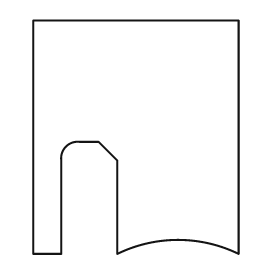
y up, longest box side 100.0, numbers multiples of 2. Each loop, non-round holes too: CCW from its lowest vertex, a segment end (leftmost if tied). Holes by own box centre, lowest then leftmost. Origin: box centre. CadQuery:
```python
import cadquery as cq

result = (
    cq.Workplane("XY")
    .moveTo(-44.0, -50.0)
    .lineTo(-32.0, -50.0)
    .lineTo(-32.0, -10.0)
    .threePointArc((-30.0, -4.0), (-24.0, -2.0))
    .lineTo(-16.0, -2.0)
    .lineTo(-8.0, -10.0)
    .lineTo(-8.0, -50.0)
    .threePointArc((18.0, -44.0), (44.0, -50.0))
    .lineTo(44.0, 50.0)
    .lineTo(-44.0, 50.0)
    .close()
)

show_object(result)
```